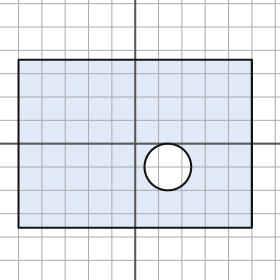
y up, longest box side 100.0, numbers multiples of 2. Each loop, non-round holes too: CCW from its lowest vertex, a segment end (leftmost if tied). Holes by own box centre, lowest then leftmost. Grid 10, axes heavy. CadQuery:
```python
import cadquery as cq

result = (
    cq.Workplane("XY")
    .moveTo(-50.0, -36.0)
    .lineTo(50.0, -36.0)
    .lineTo(50.0, 36.0)
    .lineTo(-50.0, 36.0)
    .close()
    .moveTo(14.0, -10.0)
    .circle(10.0)
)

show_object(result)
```